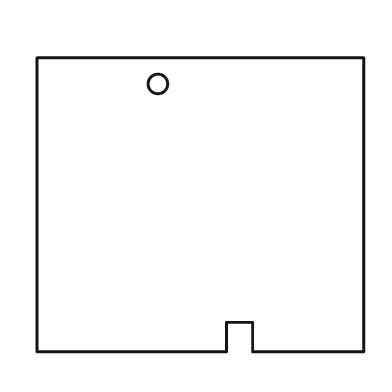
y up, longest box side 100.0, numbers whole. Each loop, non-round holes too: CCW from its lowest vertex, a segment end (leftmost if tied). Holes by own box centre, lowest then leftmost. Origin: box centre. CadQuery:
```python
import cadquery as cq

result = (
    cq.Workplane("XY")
    .moveTo(-50.0, -45.0)
    .lineTo(8.0, -45.0)
    .lineTo(8.0, -36.0)
    .lineTo(16.0, -36.0)
    .lineTo(16.0, -45.0)
    .lineTo(50.0, -45.0)
    .lineTo(50.0, 45.0)
    .lineTo(-50.0, 45.0)
    .close()
    .moveTo(-13.0, 37.0)
    .circle(3.0)
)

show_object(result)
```